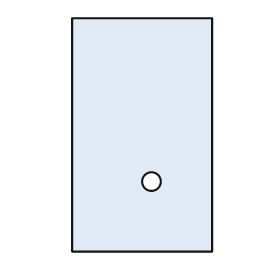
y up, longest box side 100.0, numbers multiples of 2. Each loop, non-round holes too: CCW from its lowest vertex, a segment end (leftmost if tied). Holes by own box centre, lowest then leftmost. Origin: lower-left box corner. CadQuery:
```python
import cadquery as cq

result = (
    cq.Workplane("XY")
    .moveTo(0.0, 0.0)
    .lineTo(60.0, 0.0)
    .lineTo(60.0, 100.0)
    .lineTo(0.0, 100.0)
    .close()
    .moveTo(34.0, 30.0)
    .circle(4.0)
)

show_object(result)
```